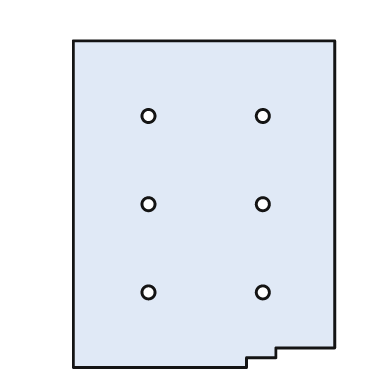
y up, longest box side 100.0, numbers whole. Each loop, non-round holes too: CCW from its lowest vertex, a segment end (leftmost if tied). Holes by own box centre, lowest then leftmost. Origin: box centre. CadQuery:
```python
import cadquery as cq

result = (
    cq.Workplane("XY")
    .moveTo(-40.0, -50.0)
    .lineTo(13.0, -50.0)
    .lineTo(13.0, -47.0)
    .lineTo(22.0, -47.0)
    .lineTo(22.0, -44.0)
    .lineTo(40.0, -44.0)
    .lineTo(40.0, 50.0)
    .lineTo(-40.0, 50.0)
    .close()
    .moveTo(-17.0, -27.0)
    .circle(2.0)
    .moveTo(18.0, -27.0)
    .circle(2.0)
    .moveTo(-17.0, 0.0)
    .circle(2.0)
    .moveTo(18.0, 0.0)
    .circle(2.0)
    .moveTo(-17.0, 27.0)
    .circle(2.0)
    .moveTo(18.0, 27.0)
    .circle(2.0)
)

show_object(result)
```